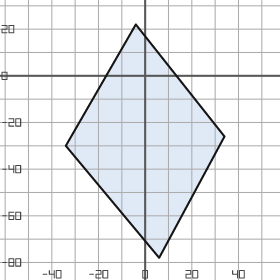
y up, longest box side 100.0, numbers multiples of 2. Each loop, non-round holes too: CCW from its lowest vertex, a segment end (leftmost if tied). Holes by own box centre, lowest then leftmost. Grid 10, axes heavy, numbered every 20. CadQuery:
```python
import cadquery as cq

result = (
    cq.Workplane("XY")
    .moveTo(6.0, -78.0)
    .lineTo(34.0, -26.0)
    .lineTo(-4.0, 22.0)
    .lineTo(-34.0, -30.0)
    .close()
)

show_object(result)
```